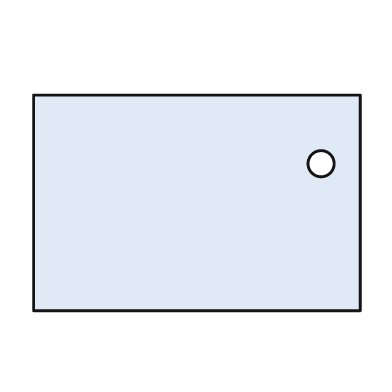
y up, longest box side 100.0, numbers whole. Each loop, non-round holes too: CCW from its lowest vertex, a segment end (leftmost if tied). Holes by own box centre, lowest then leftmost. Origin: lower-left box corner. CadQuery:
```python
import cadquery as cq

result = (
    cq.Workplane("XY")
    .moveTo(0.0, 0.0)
    .lineTo(100.0, 0.0)
    .lineTo(100.0, 66.0)
    .lineTo(0.0, 66.0)
    .close()
    .moveTo(88.0, 45.0)
    .circle(4.0)
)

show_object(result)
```